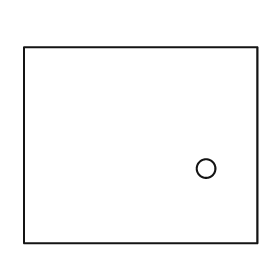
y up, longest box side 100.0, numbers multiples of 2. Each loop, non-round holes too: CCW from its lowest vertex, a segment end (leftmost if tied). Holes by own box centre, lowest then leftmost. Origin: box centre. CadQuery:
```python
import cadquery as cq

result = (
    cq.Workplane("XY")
    .moveTo(-50.0, -42.0)
    .lineTo(50.0, -42.0)
    .lineTo(50.0, 42.0)
    .lineTo(-50.0, 42.0)
    .close()
    .moveTo(28.0, -10.0)
    .circle(4.0)
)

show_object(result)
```